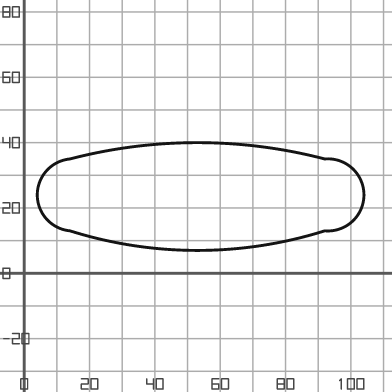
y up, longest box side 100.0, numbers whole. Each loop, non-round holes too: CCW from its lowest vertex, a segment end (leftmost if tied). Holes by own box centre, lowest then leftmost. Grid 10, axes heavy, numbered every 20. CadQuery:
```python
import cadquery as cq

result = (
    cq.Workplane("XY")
    .moveTo(14.0, 13.0)
    .threePointArc((53.0, 7.0), (92.0, 13.0))
    .threePointArc((104.0, 24.0), (92.0, 35.0))
    .threePointArc((53.0, 40.0), (14.0, 35.0))
    .threePointArc((4.0, 24.0), (14.0, 13.0))
    .close()
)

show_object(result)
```